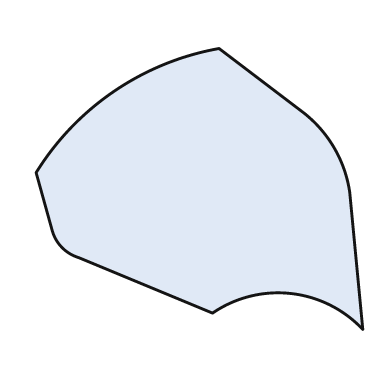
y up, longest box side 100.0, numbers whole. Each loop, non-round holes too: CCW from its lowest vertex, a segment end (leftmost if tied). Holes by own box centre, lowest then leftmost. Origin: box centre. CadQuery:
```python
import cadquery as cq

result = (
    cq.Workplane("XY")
    .moveTo(50.0, -43.0)
    .lineTo(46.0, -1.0)
    .threePointArc((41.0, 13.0), (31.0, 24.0))
    .lineTo(6.0, 43.0)
    .threePointArc((-26.0, 30.0), (-50.0, 5.0))
    .lineTo(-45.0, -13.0)
    .threePointArc((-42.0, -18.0), (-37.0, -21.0))
    .lineTo(4.0, -38.0)
    .threePointArc((28.0, -32.0), (50.0, -43.0))
    .close()
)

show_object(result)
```